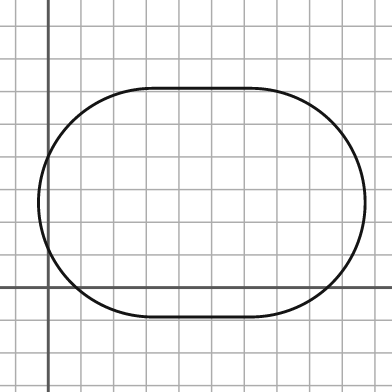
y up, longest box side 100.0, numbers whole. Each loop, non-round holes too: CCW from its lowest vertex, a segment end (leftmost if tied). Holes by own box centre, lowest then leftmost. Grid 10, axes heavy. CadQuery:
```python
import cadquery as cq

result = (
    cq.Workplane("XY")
    .moveTo(32.0, -9.0)
    .lineTo(62.0, -9.0)
    .threePointArc((97.0, 26.0), (62.0, 61.0))
    .lineTo(32.0, 61.0)
    .threePointArc((-3.0, 26.0), (32.0, -9.0))
    .close()
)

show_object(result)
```